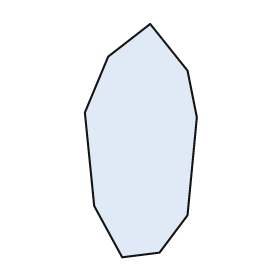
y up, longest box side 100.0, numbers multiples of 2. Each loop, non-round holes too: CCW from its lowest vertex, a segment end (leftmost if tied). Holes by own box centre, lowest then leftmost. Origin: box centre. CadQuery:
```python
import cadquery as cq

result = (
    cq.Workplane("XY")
    .moveTo(-8.0, -50.0)
    .lineTo(8.0, -48.0)
    .lineTo(20.0, -32.0)
    .lineTo(24.0, 10.0)
    .lineTo(20.0, 30.0)
    .lineTo(4.0, 50.0)
    .lineTo(-14.0, 36.0)
    .lineTo(-24.0, 12.0)
    .lineTo(-20.0, -28.0)
    .close()
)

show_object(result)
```